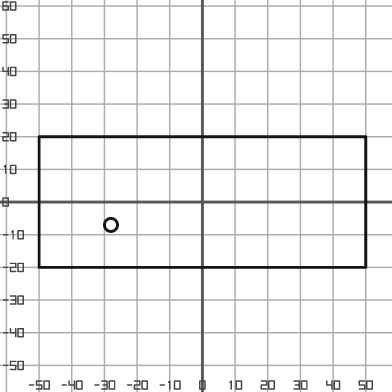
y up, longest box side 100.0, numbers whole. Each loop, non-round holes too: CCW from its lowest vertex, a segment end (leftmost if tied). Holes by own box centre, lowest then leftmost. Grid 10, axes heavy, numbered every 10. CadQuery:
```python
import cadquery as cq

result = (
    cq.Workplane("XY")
    .moveTo(-50.0, -20.0)
    .lineTo(50.0, -20.0)
    .lineTo(50.0, 20.0)
    .lineTo(-50.0, 20.0)
    .close()
    .moveTo(-28.0, -7.0)
    .circle(2.0)
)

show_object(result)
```